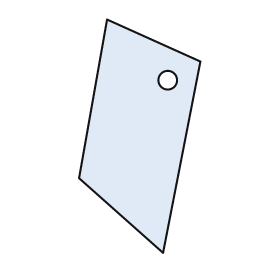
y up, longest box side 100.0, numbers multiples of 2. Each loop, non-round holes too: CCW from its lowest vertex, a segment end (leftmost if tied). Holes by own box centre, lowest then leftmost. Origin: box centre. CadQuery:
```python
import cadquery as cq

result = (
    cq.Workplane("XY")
    .moveTo(10.0, -50.0)
    .lineTo(26.0, 32.0)
    .lineTo(-14.0, 50.0)
    .lineTo(-26.0, -18.0)
    .close()
    .moveTo(12.0, 24.0)
    .circle(4.0)
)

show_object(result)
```